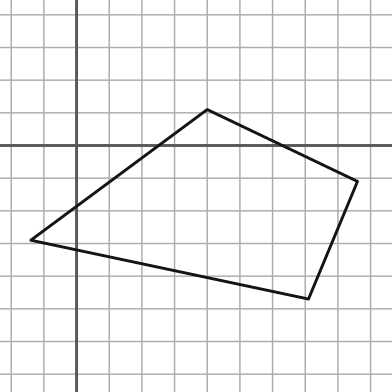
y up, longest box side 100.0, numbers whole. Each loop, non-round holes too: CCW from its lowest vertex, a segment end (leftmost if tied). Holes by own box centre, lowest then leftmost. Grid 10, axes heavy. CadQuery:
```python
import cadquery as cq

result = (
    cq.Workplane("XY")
    .moveTo(71.0, -47.0)
    .lineTo(86.0, -11.0)
    .lineTo(40.0, 11.0)
    .lineTo(-14.0, -29.0)
    .close()
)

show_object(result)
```